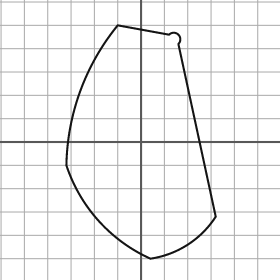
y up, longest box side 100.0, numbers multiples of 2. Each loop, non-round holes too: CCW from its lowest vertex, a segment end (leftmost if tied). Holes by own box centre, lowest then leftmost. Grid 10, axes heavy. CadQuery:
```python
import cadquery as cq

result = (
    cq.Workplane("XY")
    .moveTo(4.0, -50.0)
    .threePointArc((20.0, -44.0), (32.0, -32.0))
    .lineTo(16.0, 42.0)
    .threePointArc((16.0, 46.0), (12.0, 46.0))
    .lineTo(-10.0, 50.0)
    .threePointArc((-26.0, 22.0), (-32.0, -10.0))
    .threePointArc((-18.0, -34.0), (4.0, -50.0))
    .close()
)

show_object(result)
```